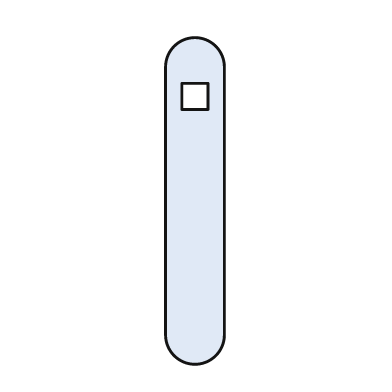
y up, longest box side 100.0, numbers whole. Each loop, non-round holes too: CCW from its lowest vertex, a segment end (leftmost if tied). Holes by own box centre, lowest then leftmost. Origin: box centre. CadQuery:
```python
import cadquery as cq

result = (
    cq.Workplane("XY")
    .moveTo(-9.0, -41.0)
    .threePointArc((0.0, -50.0), (9.0, -41.0))
    .lineTo(9.0, 41.0)
    .threePointArc((0.0, 50.0), (-9.0, 41.0))
    .close()
    .moveTo(-4.0, 28.0)
    .lineTo(4.0, 28.0)
    .lineTo(4.0, 36.0)
    .lineTo(-4.0, 36.0)
    .close()
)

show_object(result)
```